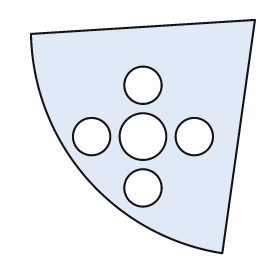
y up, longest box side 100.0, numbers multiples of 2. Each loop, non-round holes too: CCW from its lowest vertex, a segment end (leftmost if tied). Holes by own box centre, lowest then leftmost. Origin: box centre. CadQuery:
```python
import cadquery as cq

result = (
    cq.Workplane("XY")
    .moveTo(34.0, -50.0)
    .lineTo(48.0, 50.0)
    .lineTo(-48.0, 44.0)
    .threePointArc((-24.0, -18.0), (34.0, -50.0))
    .close()
    .moveTo(0.0, -22.0)
    .circle(8.0)
    .moveTo(-22.0, 0.0)
    .circle(8.0)
    .moveTo(0.0, 0.0)
    .circle(10.0)
    .moveTo(22.0, 0.0)
    .circle(8.0)
    .moveTo(0.0, 22.0)
    .circle(8.0)
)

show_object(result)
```